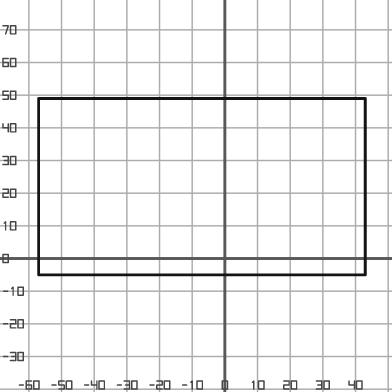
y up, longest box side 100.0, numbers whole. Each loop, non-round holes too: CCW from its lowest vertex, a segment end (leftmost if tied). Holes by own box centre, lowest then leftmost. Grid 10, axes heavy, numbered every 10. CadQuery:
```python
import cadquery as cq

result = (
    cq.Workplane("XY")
    .moveTo(-57.0, -5.0)
    .lineTo(43.0, -5.0)
    .lineTo(43.0, 49.0)
    .lineTo(-57.0, 49.0)
    .close()
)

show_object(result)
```